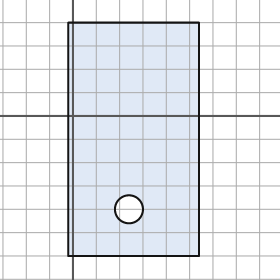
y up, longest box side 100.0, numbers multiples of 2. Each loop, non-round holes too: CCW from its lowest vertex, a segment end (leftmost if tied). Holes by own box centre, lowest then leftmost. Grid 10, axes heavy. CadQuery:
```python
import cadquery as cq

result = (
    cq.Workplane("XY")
    .moveTo(-2.0, -60.0)
    .lineTo(54.0, -60.0)
    .lineTo(54.0, 40.0)
    .lineTo(-2.0, 40.0)
    .close()
    .moveTo(24.0, -40.0)
    .circle(6.0)
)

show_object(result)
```